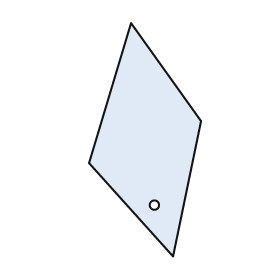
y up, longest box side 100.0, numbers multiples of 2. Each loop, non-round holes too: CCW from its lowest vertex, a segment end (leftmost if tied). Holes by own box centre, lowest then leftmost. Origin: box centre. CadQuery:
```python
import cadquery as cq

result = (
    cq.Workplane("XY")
    .moveTo(12.0, -50.0)
    .lineTo(24.0, 8.0)
    .lineTo(-6.0, 50.0)
    .lineTo(-24.0, -10.0)
    .close()
    .moveTo(4.0, -28.0)
    .circle(2.0)
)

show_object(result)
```